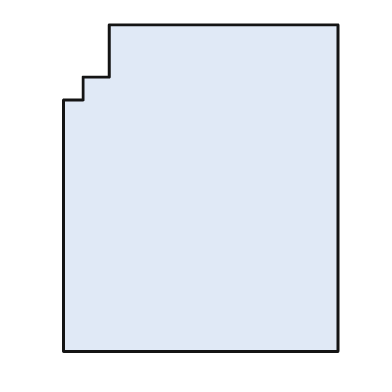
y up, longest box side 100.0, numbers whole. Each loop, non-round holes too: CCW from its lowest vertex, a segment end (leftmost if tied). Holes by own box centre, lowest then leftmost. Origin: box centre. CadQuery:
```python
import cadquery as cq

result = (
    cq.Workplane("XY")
    .moveTo(-42.0, -50.0)
    .lineTo(42.0, -50.0)
    .lineTo(42.0, 50.0)
    .lineTo(-28.0, 50.0)
    .lineTo(-28.0, 34.0)
    .lineTo(-36.0, 34.0)
    .lineTo(-36.0, 27.0)
    .lineTo(-42.0, 27.0)
    .close()
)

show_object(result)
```